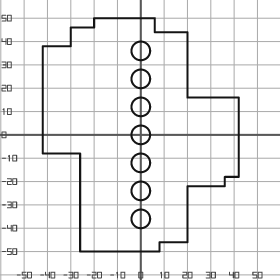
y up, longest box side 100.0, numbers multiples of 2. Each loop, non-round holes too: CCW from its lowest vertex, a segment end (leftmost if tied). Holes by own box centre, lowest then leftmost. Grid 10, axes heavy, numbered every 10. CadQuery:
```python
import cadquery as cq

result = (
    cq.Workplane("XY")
    .moveTo(-26.0, -50.0)
    .lineTo(8.0, -50.0)
    .lineTo(8.0, -46.0)
    .lineTo(20.0, -46.0)
    .lineTo(20.0, -22.0)
    .lineTo(36.0, -22.0)
    .lineTo(36.0, -18.0)
    .lineTo(42.0, -18.0)
    .lineTo(42.0, 16.0)
    .lineTo(20.0, 16.0)
    .lineTo(20.0, 44.0)
    .lineTo(6.0, 44.0)
    .lineTo(6.0, 50.0)
    .lineTo(-20.0, 50.0)
    .lineTo(-20.0, 46.0)
    .lineTo(-30.0, 46.0)
    .lineTo(-30.0, 38.0)
    .lineTo(-42.0, 38.0)
    .lineTo(-42.0, -8.0)
    .lineTo(-26.0, -8.0)
    .close()
    .moveTo(0.0, -36.0)
    .circle(4.0)
    .moveTo(0.0, -24.0)
    .circle(4.0)
    .moveTo(0.0, -12.0)
    .circle(4.0)
    .moveTo(0.0, 0.0)
    .circle(4.0)
    .moveTo(0.0, 12.0)
    .circle(4.0)
    .moveTo(0.0, 24.0)
    .circle(4.0)
    .moveTo(0.0, 36.0)
    .circle(4.0)
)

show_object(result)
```